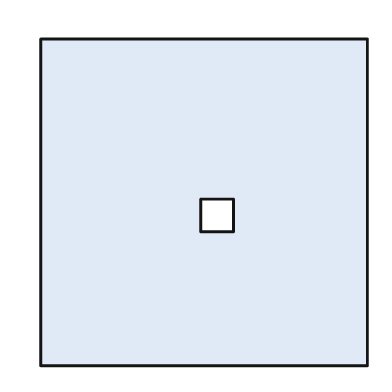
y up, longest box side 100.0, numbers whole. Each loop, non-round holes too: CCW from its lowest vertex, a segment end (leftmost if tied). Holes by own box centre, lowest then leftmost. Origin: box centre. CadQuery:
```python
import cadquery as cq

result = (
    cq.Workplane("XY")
    .moveTo(-50.0, -50.0)
    .lineTo(50.0, -50.0)
    .lineTo(50.0, 50.0)
    .lineTo(-50.0, 50.0)
    .close()
    .moveTo(-1.0, -9.0)
    .lineTo(9.0, -9.0)
    .lineTo(9.0, 1.0)
    .lineTo(-1.0, 1.0)
    .close()
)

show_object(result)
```